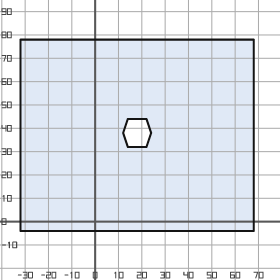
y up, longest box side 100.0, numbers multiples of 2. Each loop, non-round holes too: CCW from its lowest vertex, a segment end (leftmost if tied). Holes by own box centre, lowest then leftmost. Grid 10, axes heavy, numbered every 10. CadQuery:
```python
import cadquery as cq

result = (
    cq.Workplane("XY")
    .moveTo(-32.0, -4.0)
    .lineTo(68.0, -4.0)
    .lineTo(68.0, 78.0)
    .lineTo(-32.0, 78.0)
    .close()
    .moveTo(14.0, 32.0)
    .lineTo(22.0, 32.0)
    .lineTo(24.0, 38.0)
    .lineTo(22.0, 44.0)
    .lineTo(14.0, 44.0)
    .lineTo(12.0, 38.0)
    .close()
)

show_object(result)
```